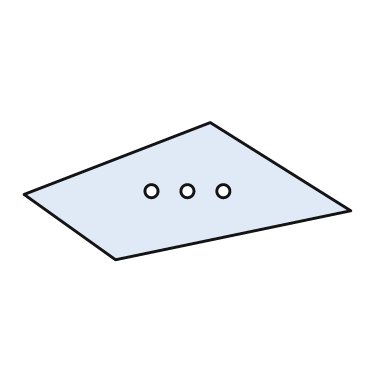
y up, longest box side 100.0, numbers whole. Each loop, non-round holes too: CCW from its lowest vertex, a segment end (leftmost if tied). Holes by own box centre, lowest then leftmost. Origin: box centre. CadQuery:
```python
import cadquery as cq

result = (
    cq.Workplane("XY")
    .moveTo(-22.0, -21.0)
    .lineTo(50.0, -6.0)
    .lineTo(7.0, 21.0)
    .lineTo(-50.0, -1.0)
    .close()
    .moveTo(-11.0, 0.0)
    .circle(2.0)
    .moveTo(0.0, 0.0)
    .circle(2.0)
    .moveTo(11.0, 0.0)
    .circle(2.0)
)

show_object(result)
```